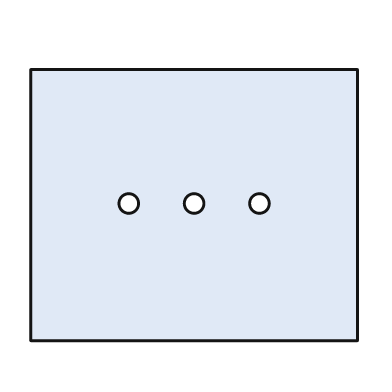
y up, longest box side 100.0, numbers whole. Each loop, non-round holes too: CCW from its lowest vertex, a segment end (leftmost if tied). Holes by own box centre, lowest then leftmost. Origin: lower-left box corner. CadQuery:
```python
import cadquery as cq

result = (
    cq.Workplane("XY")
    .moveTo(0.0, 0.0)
    .lineTo(100.0, 0.0)
    .lineTo(100.0, 83.0)
    .lineTo(0.0, 83.0)
    .close()
    .moveTo(30.0, 42.0)
    .circle(3.0)
    .moveTo(50.0, 42.0)
    .circle(3.0)
    .moveTo(70.0, 42.0)
    .circle(3.0)
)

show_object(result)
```